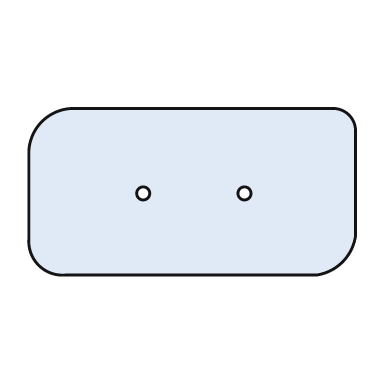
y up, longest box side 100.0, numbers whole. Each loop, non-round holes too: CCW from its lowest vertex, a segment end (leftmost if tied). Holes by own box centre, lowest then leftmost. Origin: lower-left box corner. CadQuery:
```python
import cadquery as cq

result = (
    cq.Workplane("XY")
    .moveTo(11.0, 0.0)
    .lineTo(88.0, 0.0)
    .threePointArc((96.0, 4.0), (100.0, 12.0))
    .lineTo(100.0, 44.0)
    .threePointArc((98.0, 49.0), (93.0, 51.0))
    .lineTo(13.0, 51.0)
    .threePointArc((4.0, 47.0), (0.0, 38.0))
    .lineTo(0.0, 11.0)
    .threePointArc((3.0, 3.0), (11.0, 0.0))
    .close()
    .moveTo(35.0, 25.0)
    .circle(2.0)
    .moveTo(66.0, 25.0)
    .circle(2.0)
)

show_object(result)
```